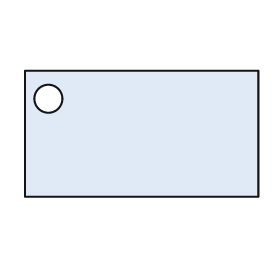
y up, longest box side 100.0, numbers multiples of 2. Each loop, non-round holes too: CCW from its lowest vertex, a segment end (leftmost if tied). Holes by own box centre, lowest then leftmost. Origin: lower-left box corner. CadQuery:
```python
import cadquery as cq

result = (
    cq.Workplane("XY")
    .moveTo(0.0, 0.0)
    .lineTo(100.0, 0.0)
    .lineTo(100.0, 54.0)
    .lineTo(0.0, 54.0)
    .close()
    .moveTo(10.0, 42.0)
    .circle(6.0)
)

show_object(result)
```